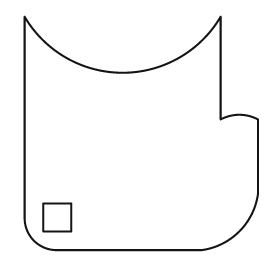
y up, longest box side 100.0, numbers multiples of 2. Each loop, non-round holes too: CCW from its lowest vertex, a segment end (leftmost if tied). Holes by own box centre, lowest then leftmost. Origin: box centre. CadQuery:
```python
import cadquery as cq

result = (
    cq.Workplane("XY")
    .moveTo(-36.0, -50.0)
    .lineTo(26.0, -50.0)
    .threePointArc((42.0, -42.0), (50.0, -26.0))
    .lineTo(50.0, 6.0)
    .threePointArc((42.0, 8.0), (34.0, 6.0))
    .lineTo(34.0, 50.0)
    .threePointArc((-8.0, 26.0), (-50.0, 50.0))
    .lineTo(-50.0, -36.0)
    .threePointArc((-46.0, -46.0), (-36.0, -50.0))
    .close()
    .moveTo(-42.0, -42.0)
    .lineTo(-30.0, -42.0)
    .lineTo(-30.0, -30.0)
    .lineTo(-42.0, -30.0)
    .close()
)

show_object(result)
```